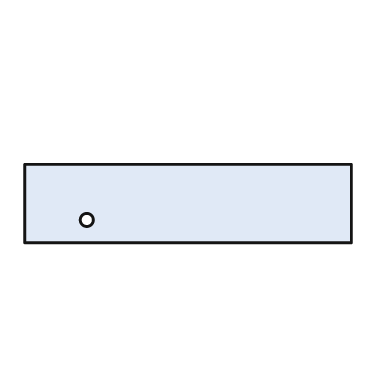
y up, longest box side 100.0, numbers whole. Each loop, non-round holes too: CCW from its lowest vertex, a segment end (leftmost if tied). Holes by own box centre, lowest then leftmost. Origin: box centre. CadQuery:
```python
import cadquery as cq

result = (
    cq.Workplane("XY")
    .moveTo(-50.0, -12.0)
    .lineTo(50.0, -12.0)
    .lineTo(50.0, 12.0)
    .lineTo(-50.0, 12.0)
    .close()
    .moveTo(-31.0, -5.0)
    .circle(2.0)
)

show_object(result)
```